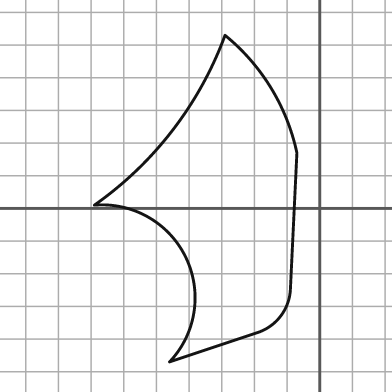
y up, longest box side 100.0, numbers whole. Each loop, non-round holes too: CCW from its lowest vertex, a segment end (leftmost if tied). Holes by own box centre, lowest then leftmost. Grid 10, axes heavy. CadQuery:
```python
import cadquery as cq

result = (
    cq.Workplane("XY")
    .moveTo(-46.0, -47.0)
    .lineTo(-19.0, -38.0)
    .threePointArc((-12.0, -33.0), (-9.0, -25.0))
    .lineTo(-7.0, 17.0)
    .threePointArc((-15.0, 37.0), (-29.0, 53.0))
    .threePointArc((-45.0, 24.0), (-69.0, 1.0))
    .threePointArc((-41.0, -15.0), (-46.0, -47.0))
    .close()
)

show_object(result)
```